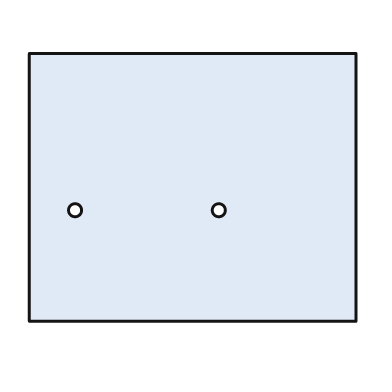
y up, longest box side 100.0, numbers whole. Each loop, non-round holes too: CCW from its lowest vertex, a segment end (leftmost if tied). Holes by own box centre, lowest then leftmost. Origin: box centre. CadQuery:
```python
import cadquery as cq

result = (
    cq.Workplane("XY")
    .moveTo(-50.0, -41.0)
    .lineTo(50.0, -41.0)
    .lineTo(50.0, 41.0)
    .lineTo(-50.0, 41.0)
    .close()
    .moveTo(-36.0, -7.0)
    .circle(2.0)
    .moveTo(8.0, -7.0)
    .circle(2.0)
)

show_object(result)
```